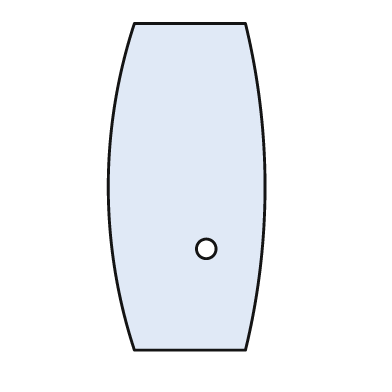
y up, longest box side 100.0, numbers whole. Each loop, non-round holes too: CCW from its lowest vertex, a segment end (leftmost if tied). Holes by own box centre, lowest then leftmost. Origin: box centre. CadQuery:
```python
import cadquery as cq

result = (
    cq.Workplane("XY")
    .moveTo(-16.0, -50.0)
    .lineTo(18.0, -50.0)
    .threePointArc((24.0, 0.0), (18.0, 50.0))
    .lineTo(-16.0, 50.0)
    .threePointArc((-24.0, 0.0), (-16.0, -50.0))
    .close()
    .moveTo(6.0, -19.0)
    .circle(3.0)
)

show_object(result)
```